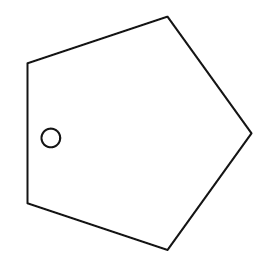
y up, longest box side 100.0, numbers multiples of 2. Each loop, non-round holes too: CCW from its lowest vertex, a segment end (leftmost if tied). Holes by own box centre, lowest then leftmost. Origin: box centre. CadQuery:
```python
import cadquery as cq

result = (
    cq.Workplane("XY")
    .moveTo(12.0, -50.0)
    .lineTo(48.0, 0.0)
    .lineTo(12.0, 50.0)
    .lineTo(-48.0, 30.0)
    .lineTo(-48.0, -30.0)
    .close()
    .moveTo(-38.0, -2.0)
    .circle(4.0)
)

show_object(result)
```